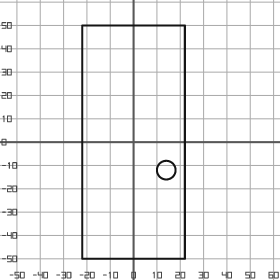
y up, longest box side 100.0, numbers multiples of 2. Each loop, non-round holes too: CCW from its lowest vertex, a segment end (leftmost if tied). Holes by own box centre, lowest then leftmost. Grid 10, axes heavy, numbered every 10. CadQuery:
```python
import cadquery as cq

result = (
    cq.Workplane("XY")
    .moveTo(-22.0, -50.0)
    .lineTo(22.0, -50.0)
    .lineTo(22.0, 50.0)
    .lineTo(-22.0, 50.0)
    .close()
    .moveTo(14.0, -12.0)
    .circle(4.0)
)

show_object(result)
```